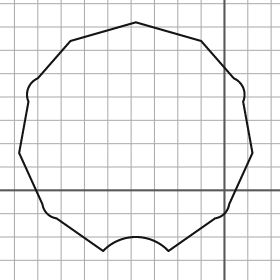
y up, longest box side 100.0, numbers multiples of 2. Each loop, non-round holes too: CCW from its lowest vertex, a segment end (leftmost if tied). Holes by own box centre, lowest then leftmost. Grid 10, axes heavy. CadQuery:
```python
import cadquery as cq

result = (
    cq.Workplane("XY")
    .moveTo(-52.0, -26.0)
    .threePointArc((-38.0, -20.0), (-24.0, -26.0))
    .lineTo(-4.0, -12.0)
    .threePointArc((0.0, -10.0), (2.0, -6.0))
    .lineTo(12.0, 16.0)
    .lineTo(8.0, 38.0)
    .threePointArc((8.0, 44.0), (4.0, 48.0))
    .lineTo(-10.0, 64.0)
    .lineTo(-38.0, 72.0)
    .lineTo(-66.0, 64.0)
    .lineTo(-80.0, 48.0)
    .threePointArc((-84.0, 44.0), (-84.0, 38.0))
    .lineTo(-88.0, 16.0)
    .lineTo(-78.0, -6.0)
    .threePointArc((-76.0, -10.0), (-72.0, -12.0))
    .close()
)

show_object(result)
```